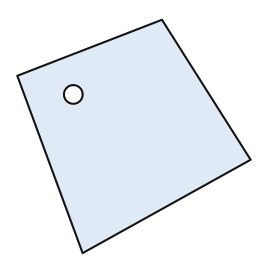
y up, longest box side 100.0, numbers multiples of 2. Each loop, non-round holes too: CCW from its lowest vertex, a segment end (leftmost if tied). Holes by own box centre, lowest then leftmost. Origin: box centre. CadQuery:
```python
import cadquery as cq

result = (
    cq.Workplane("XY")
    .moveTo(-22.0, -50.0)
    .lineTo(50.0, -10.0)
    .lineTo(12.0, 50.0)
    .lineTo(-50.0, 26.0)
    .close()
    .moveTo(-26.0, 18.0)
    .circle(4.0)
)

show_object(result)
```